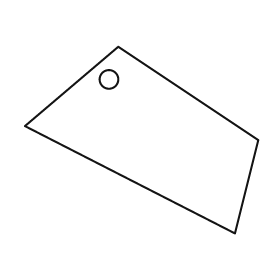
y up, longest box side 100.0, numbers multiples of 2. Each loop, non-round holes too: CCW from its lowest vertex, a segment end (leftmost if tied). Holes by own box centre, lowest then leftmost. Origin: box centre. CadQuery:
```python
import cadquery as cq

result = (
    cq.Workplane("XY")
    .moveTo(40.0, -40.0)
    .lineTo(50.0, 0.0)
    .lineTo(-10.0, 40.0)
    .lineTo(-50.0, 6.0)
    .close()
    .moveTo(-14.0, 26.0)
    .circle(4.0)
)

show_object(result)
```